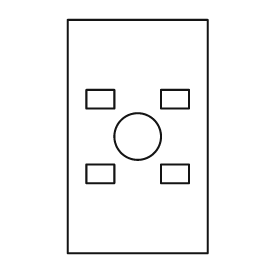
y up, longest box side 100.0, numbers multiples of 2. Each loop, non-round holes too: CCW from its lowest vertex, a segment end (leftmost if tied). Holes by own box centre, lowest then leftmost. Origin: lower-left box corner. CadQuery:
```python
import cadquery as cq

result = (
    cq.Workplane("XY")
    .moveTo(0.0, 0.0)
    .lineTo(60.0, 0.0)
    .lineTo(60.0, 100.0)
    .lineTo(0.0, 100.0)
    .close()
    .moveTo(8.0, 30.0)
    .lineTo(20.0, 30.0)
    .lineTo(20.0, 38.0)
    .lineTo(8.0, 38.0)
    .close()
    .moveTo(40.0, 30.0)
    .lineTo(52.0, 30.0)
    .lineTo(52.0, 38.0)
    .lineTo(40.0, 38.0)
    .close()
    .moveTo(30.0, 50.0)
    .circle(10.0)
    .moveTo(8.0, 62.0)
    .lineTo(20.0, 62.0)
    .lineTo(20.0, 70.0)
    .lineTo(8.0, 70.0)
    .close()
    .moveTo(40.0, 62.0)
    .lineTo(52.0, 62.0)
    .lineTo(52.0, 70.0)
    .lineTo(40.0, 70.0)
    .close()
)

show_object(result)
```